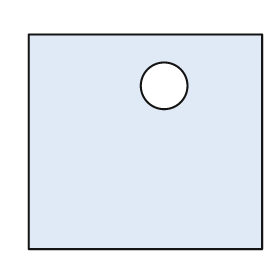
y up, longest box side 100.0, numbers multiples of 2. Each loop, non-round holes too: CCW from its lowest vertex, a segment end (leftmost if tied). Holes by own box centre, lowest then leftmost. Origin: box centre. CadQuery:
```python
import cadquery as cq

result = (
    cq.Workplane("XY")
    .moveTo(-50.0, -46.0)
    .lineTo(50.0, -46.0)
    .lineTo(50.0, 46.0)
    .lineTo(-50.0, 46.0)
    .close()
    .moveTo(8.0, 24.0)
    .circle(10.0)
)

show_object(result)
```